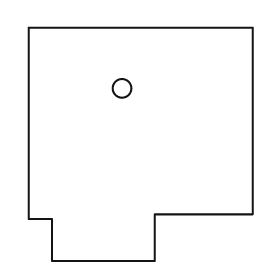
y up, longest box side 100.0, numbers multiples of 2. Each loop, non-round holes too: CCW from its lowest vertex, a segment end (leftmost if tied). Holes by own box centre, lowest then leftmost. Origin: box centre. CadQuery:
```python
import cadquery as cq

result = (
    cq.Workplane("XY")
    .moveTo(-38.0, -50.0)
    .lineTo(6.0, -50.0)
    .lineTo(6.0, -30.0)
    .lineTo(48.0, -30.0)
    .lineTo(48.0, 50.0)
    .lineTo(-48.0, 50.0)
    .lineTo(-48.0, -32.0)
    .lineTo(-38.0, -32.0)
    .close()
    .moveTo(-8.0, 24.0)
    .circle(4.0)
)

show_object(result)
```